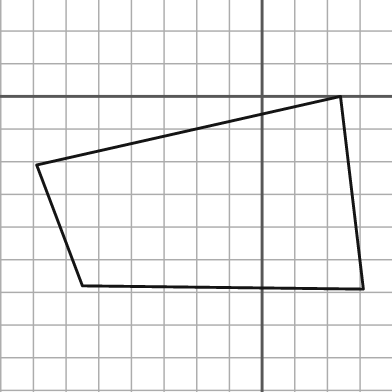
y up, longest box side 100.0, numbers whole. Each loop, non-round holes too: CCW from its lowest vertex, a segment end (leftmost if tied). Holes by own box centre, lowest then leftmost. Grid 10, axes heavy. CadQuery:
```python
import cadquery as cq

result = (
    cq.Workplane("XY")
    .moveTo(31.0, -59.0)
    .lineTo(24.0, 0.0)
    .lineTo(-69.0, -21.0)
    .lineTo(-55.0, -58.0)
    .close()
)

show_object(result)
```